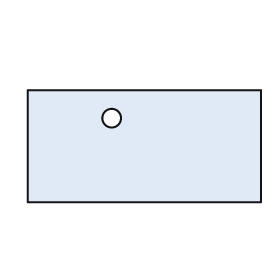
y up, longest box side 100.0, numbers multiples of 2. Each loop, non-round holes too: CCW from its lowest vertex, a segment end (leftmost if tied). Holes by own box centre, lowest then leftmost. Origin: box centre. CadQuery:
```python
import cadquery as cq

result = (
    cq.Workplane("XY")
    .moveTo(-50.0, -24.0)
    .lineTo(50.0, -24.0)
    .lineTo(50.0, 24.0)
    .lineTo(-50.0, 24.0)
    .close()
    .moveTo(-14.0, 12.0)
    .circle(4.0)
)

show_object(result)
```